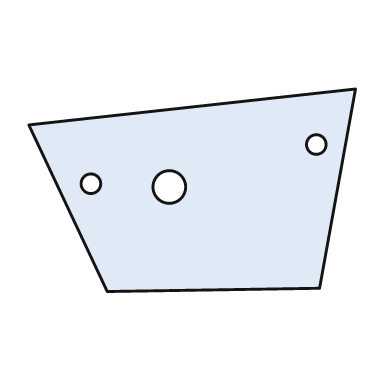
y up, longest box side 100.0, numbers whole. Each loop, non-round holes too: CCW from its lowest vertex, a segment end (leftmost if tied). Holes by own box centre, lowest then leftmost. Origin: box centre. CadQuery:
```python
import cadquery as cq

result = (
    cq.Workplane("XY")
    .moveTo(-26.0, -31.0)
    .lineTo(39.0, -30.0)
    .lineTo(50.0, 31.0)
    .lineTo(-50.0, 20.0)
    .close()
    .moveTo(-7.0, 1.0)
    .circle(5.0)
    .moveTo(-31.0, 2.0)
    .circle(3.0)
    .moveTo(38.0, 14.0)
    .circle(3.0)
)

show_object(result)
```